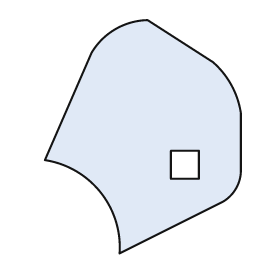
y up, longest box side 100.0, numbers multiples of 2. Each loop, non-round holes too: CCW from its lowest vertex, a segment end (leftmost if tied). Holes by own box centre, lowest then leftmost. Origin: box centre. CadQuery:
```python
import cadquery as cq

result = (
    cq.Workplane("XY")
    .moveTo(-10.0, -50.0)
    .lineTo(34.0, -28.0)
    .threePointArc((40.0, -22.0), (42.0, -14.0))
    .lineTo(42.0, 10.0)
    .threePointArc((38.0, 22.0), (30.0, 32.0))
    .lineTo(2.0, 50.0)
    .threePointArc((-12.0, 46.0), (-22.0, 36.0))
    .lineTo(-42.0, -10.0)
    .threePointArc((-18.0, -24.0), (-10.0, -50.0))
    .close()
    .moveTo(12.0, -18.0)
    .lineTo(24.0, -18.0)
    .lineTo(24.0, -6.0)
    .lineTo(12.0, -6.0)
    .close()
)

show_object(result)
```